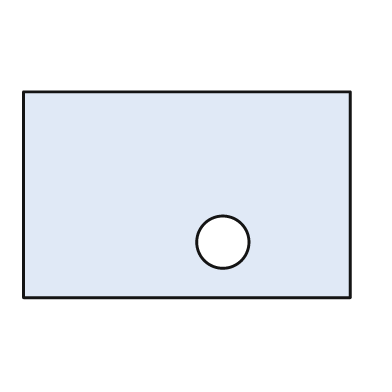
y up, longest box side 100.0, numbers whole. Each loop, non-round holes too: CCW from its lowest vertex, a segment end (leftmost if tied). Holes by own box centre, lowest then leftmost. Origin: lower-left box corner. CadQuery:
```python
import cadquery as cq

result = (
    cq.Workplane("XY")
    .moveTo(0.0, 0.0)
    .lineTo(100.0, 0.0)
    .lineTo(100.0, 63.0)
    .lineTo(0.0, 63.0)
    .close()
    .moveTo(61.0, 17.0)
    .circle(8.0)
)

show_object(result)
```